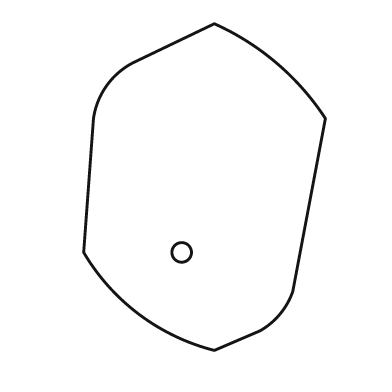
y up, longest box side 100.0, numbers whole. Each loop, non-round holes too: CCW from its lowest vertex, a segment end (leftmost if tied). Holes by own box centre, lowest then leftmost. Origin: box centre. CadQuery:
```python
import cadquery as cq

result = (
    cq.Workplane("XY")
    .moveTo(3.0, -50.0)
    .lineTo(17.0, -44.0)
    .threePointArc((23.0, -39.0), (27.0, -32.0))
    .lineTo(37.0, 21.0)
    .threePointArc((22.0, 38.0), (3.0, 50.0))
    .lineTo(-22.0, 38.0)
    .threePointArc((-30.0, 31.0), (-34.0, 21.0))
    .lineTo(-37.0, -20.0)
    .threePointArc((-20.0, -39.0), (3.0, -50.0))
    .close()
    .moveTo(-7.0, -20.0)
    .circle(3.0)
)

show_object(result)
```